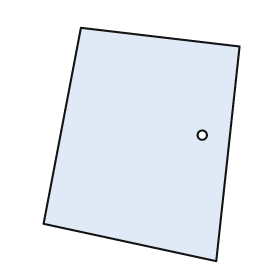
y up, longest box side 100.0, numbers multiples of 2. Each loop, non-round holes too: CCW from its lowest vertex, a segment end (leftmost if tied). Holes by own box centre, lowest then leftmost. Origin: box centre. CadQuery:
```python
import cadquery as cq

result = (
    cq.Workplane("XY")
    .moveTo(32.0, -50.0)
    .lineTo(42.0, 42.0)
    .lineTo(-26.0, 50.0)
    .lineTo(-42.0, -34.0)
    .close()
    .moveTo(26.0, 4.0)
    .circle(2.0)
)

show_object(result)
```